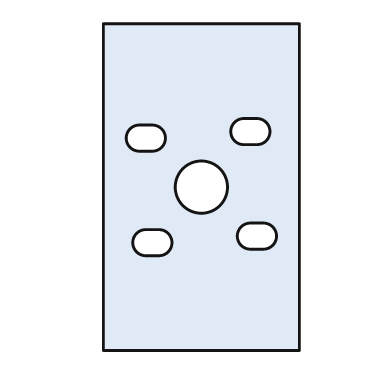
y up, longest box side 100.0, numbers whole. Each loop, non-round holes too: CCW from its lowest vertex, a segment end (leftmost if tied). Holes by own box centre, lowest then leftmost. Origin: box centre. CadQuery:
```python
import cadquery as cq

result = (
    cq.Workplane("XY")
    .moveTo(-30.0, -50.0)
    .lineTo(30.0, -50.0)
    .lineTo(30.0, 50.0)
    .lineTo(-30.0, 50.0)
    .close()
    .moveTo(-17.0, -21.0)
    .lineTo(-13.0, -21.0)
    .threePointArc((-9.0, -17.0), (-13.0, -13.0))
    .lineTo(-17.0, -13.0)
    .threePointArc((-21.0, -17.0), (-17.0, -21.0))
    .close()
    .moveTo(15.0, -19.0)
    .lineTo(19.0, -19.0)
    .threePointArc((23.0, -15.0), (19.0, -11.0))
    .lineTo(15.0, -11.0)
    .threePointArc((11.0, -15.0), (15.0, -19.0))
    .close()
    .moveTo(0.0, 0.0)
    .circle(8.0)
    .moveTo(-19.0, 11.0)
    .lineTo(-15.0, 11.0)
    .threePointArc((-11.0, 15.0), (-15.0, 19.0))
    .lineTo(-19.0, 19.0)
    .threePointArc((-23.0, 15.0), (-19.0, 11.0))
    .close()
    .moveTo(13.0, 13.0)
    .lineTo(17.0, 13.0)
    .threePointArc((21.0, 17.0), (17.0, 21.0))
    .lineTo(13.0, 21.0)
    .threePointArc((9.0, 17.0), (13.0, 13.0))
    .close()
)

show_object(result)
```